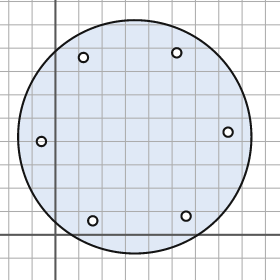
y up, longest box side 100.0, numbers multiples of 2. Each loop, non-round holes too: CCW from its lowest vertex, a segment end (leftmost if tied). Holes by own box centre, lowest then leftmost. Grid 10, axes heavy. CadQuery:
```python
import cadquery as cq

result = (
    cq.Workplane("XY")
    .moveTo(34.0, 42.0)
    .circle(50.0)
    .moveTo(16.0, 6.0)
    .circle(2.0)
    .moveTo(56.0, 8.0)
    .circle(2.0)
    .moveTo(-6.0, 40.0)
    .circle(2.0)
    .moveTo(74.0, 44.0)
    .circle(2.0)
    .moveTo(12.0, 76.0)
    .circle(2.0)
    .moveTo(52.0, 78.0)
    .circle(2.0)
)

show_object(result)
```